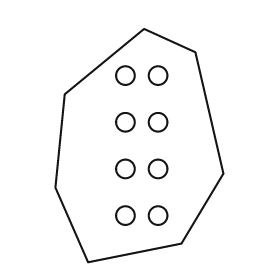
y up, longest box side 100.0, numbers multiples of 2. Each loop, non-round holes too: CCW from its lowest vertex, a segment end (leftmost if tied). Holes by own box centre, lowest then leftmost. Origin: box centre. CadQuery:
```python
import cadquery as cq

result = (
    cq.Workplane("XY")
    .moveTo(-22.0, -50.0)
    .lineTo(18.0, -42.0)
    .lineTo(36.0, -12.0)
    .lineTo(24.0, 40.0)
    .lineTo(2.0, 50.0)
    .lineTo(-32.0, 22.0)
    .lineTo(-36.0, -18.0)
    .close()
    .moveTo(-6.0, -30.0)
    .circle(4.0)
    .moveTo(8.0, -30.0)
    .circle(4.0)
    .moveTo(-6.0, -10.0)
    .circle(4.0)
    .moveTo(8.0, -10.0)
    .circle(4.0)
    .moveTo(-6.0, 10.0)
    .circle(4.0)
    .moveTo(8.0, 10.0)
    .circle(4.0)
    .moveTo(-6.0, 30.0)
    .circle(4.0)
    .moveTo(8.0, 30.0)
    .circle(4.0)
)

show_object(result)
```